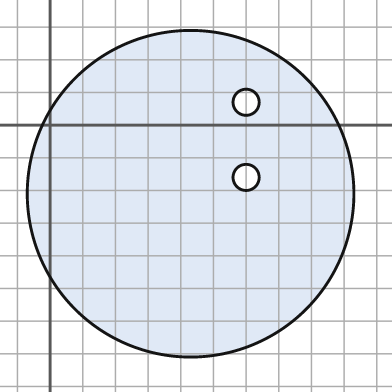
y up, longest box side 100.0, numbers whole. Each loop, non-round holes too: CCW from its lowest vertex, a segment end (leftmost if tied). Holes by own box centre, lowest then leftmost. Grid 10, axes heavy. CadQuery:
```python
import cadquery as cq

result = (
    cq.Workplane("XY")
    .moveTo(43.0, -21.0)
    .circle(50.0)
    .moveTo(60.0, -16.0)
    .circle(4.0)
    .moveTo(60.0, 7.0)
    .circle(4.0)
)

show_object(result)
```